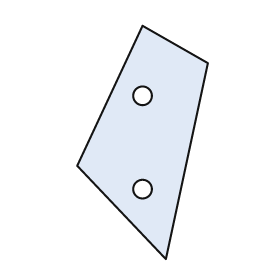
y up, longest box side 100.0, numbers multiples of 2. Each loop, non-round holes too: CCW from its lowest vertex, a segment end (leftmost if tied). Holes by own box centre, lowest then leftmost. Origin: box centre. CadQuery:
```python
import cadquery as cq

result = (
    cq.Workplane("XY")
    .moveTo(10.0, -50.0)
    .lineTo(28.0, 34.0)
    .lineTo(0.0, 50.0)
    .lineTo(-28.0, -10.0)
    .close()
    .moveTo(0.0, -20.0)
    .circle(4.0)
    .moveTo(0.0, 20.0)
    .circle(4.0)
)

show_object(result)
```